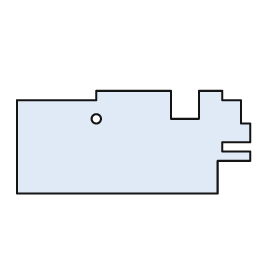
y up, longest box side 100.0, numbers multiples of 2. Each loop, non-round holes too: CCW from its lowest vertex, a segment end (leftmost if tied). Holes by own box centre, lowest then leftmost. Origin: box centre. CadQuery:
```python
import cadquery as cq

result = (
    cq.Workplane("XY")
    .moveTo(-50.0, -22.0)
    .lineTo(36.0, -22.0)
    .lineTo(36.0, -8.0)
    .lineTo(50.0, -8.0)
    .lineTo(50.0, -4.0)
    .lineTo(38.0, -4.0)
    .lineTo(38.0, 0.0)
    .lineTo(50.0, 0.0)
    .lineTo(50.0, 8.0)
    .lineTo(46.0, 8.0)
    .lineTo(46.0, 18.0)
    .lineTo(38.0, 18.0)
    .lineTo(38.0, 22.0)
    .lineTo(28.0, 22.0)
    .lineTo(28.0, 10.0)
    .lineTo(16.0, 10.0)
    .lineTo(16.0, 22.0)
    .lineTo(-16.0, 22.0)
    .lineTo(-16.0, 18.0)
    .lineTo(-50.0, 18.0)
    .close()
    .moveTo(-16.0, 10.0)
    .circle(2.0)
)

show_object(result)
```